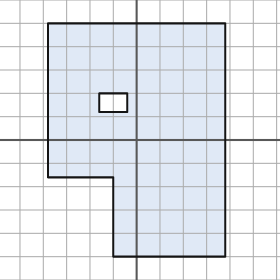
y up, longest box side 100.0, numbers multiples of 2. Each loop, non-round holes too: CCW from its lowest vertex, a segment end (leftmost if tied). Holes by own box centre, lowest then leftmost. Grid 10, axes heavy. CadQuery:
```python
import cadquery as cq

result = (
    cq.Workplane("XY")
    .moveTo(-10.0, -50.0)
    .lineTo(38.0, -50.0)
    .lineTo(38.0, 50.0)
    .lineTo(-38.0, 50.0)
    .lineTo(-38.0, -16.0)
    .lineTo(-10.0, -16.0)
    .close()
    .moveTo(-16.0, 12.0)
    .lineTo(-4.0, 12.0)
    .lineTo(-4.0, 20.0)
    .lineTo(-16.0, 20.0)
    .close()
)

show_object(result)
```